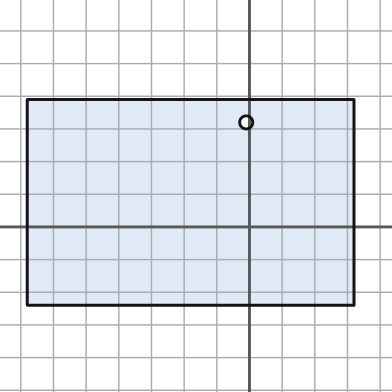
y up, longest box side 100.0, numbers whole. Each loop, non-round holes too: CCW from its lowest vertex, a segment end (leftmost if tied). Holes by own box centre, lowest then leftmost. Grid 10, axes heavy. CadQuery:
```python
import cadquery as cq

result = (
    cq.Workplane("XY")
    .moveTo(-68.0, -24.0)
    .lineTo(32.0, -24.0)
    .lineTo(32.0, 39.0)
    .lineTo(-68.0, 39.0)
    .close()
    .moveTo(-1.0, 32.0)
    .circle(2.0)
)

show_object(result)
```